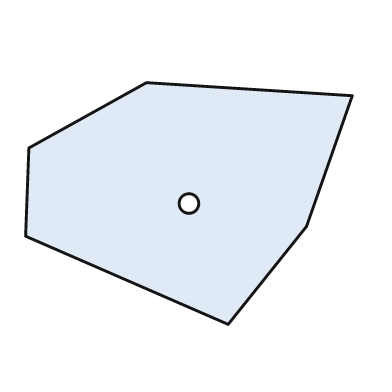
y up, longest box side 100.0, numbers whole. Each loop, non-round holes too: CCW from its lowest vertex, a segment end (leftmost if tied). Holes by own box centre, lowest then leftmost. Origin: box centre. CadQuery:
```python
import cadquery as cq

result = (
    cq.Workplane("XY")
    .moveTo(12.0, -37.0)
    .lineTo(36.0, -7.0)
    .lineTo(50.0, 33.0)
    .lineTo(-13.0, 37.0)
    .lineTo(-49.0, 17.0)
    .lineTo(-50.0, -10.0)
    .close()
    .moveTo(0.0, 0.0)
    .circle(3.0)
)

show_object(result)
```